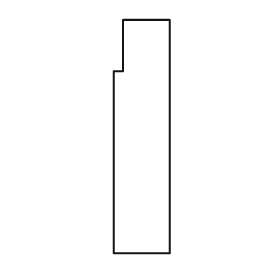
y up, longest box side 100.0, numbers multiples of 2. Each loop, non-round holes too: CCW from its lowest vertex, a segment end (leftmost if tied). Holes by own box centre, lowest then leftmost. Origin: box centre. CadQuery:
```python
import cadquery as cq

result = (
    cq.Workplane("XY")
    .moveTo(-12.0, -50.0)
    .lineTo(12.0, -50.0)
    .lineTo(12.0, 50.0)
    .lineTo(-8.0, 50.0)
    .lineTo(-8.0, 28.0)
    .lineTo(-12.0, 28.0)
    .close()
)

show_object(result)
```